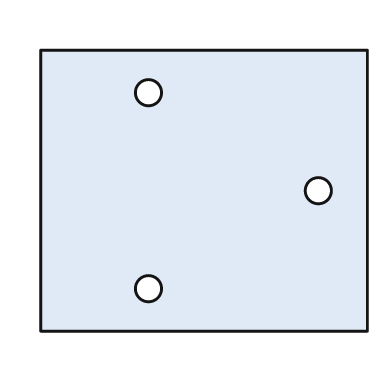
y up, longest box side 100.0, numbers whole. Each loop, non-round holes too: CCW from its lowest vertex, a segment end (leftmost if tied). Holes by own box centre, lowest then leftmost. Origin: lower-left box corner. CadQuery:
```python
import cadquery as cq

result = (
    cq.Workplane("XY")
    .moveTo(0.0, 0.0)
    .lineTo(100.0, 0.0)
    .lineTo(100.0, 86.0)
    .lineTo(0.0, 86.0)
    .close()
    .moveTo(33.0, 13.0)
    .circle(4.0)
    .moveTo(85.0, 43.0)
    .circle(4.0)
    .moveTo(33.0, 73.0)
    .circle(4.0)
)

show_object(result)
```